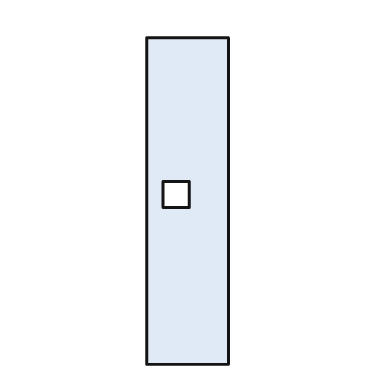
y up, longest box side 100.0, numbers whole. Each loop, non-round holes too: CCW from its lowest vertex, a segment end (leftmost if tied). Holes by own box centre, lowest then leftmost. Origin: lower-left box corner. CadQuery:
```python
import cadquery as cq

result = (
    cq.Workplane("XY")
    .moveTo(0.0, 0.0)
    .lineTo(25.0, 0.0)
    .lineTo(25.0, 100.0)
    .lineTo(0.0, 100.0)
    .close()
    .moveTo(5.0, 48.0)
    .lineTo(13.0, 48.0)
    .lineTo(13.0, 56.0)
    .lineTo(5.0, 56.0)
    .close()
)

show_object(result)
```